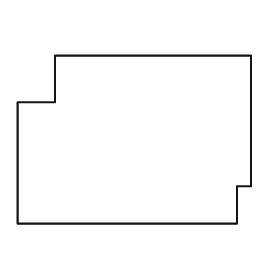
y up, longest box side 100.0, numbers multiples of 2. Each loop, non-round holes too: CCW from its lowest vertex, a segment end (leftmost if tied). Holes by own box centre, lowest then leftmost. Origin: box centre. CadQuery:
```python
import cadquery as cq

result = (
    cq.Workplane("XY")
    .moveTo(-50.0, -36.0)
    .lineTo(44.0, -36.0)
    .lineTo(44.0, -20.0)
    .lineTo(50.0, -20.0)
    .lineTo(50.0, 36.0)
    .lineTo(-34.0, 36.0)
    .lineTo(-34.0, 16.0)
    .lineTo(-50.0, 16.0)
    .close()
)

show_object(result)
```